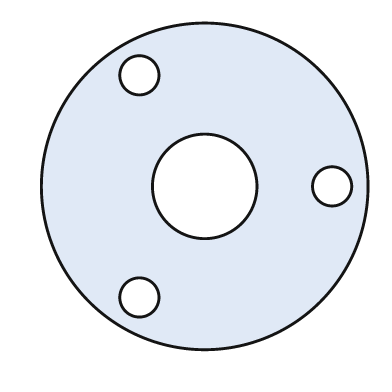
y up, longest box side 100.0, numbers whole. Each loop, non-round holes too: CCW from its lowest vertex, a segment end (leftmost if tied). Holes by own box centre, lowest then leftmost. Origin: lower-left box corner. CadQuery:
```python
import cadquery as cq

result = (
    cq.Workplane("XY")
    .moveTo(50.0, 50.0)
    .circle(50.0)
    .moveTo(30.0, 16.0)
    .circle(6.0)
    .moveTo(50.0, 50.0)
    .circle(16.0)
    .moveTo(89.0, 50.0)
    .circle(6.0)
    .moveTo(30.0, 84.0)
    .circle(6.0)
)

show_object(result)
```